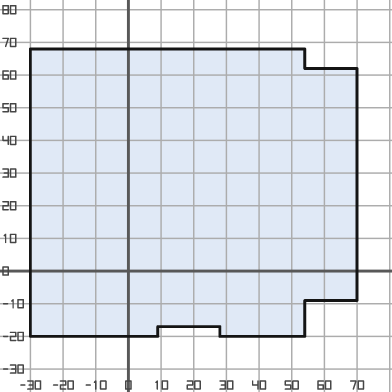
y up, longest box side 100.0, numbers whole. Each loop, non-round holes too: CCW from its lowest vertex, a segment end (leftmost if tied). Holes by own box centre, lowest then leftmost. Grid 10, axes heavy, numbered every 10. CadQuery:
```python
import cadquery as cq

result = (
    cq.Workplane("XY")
    .moveTo(-30.0, -20.0)
    .lineTo(9.0, -20.0)
    .lineTo(9.0, -17.0)
    .lineTo(28.0, -17.0)
    .lineTo(28.0, -20.0)
    .lineTo(54.0, -20.0)
    .lineTo(54.0, -9.0)
    .lineTo(70.0, -9.0)
    .lineTo(70.0, 62.0)
    .lineTo(54.0, 62.0)
    .lineTo(54.0, 68.0)
    .lineTo(-30.0, 68.0)
    .close()
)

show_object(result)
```